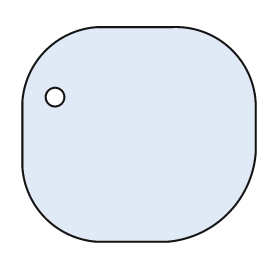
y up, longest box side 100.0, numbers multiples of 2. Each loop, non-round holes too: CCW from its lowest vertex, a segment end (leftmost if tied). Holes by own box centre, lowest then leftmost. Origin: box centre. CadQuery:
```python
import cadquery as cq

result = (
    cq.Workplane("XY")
    .moveTo(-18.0, -46.0)
    .lineTo(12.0, -46.0)
    .threePointArc((38.0, -34.0), (50.0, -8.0))
    .lineTo(50.0, 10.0)
    .threePointArc((40.0, 36.0), (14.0, 46.0))
    .lineTo(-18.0, 46.0)
    .threePointArc((-40.0, 36.0), (-50.0, 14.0))
    .lineTo(-50.0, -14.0)
    .threePointArc((-40.0, -36.0), (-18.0, -46.0))
    .close()
    .moveTo(-36.0, 16.0)
    .circle(4.0)
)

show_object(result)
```